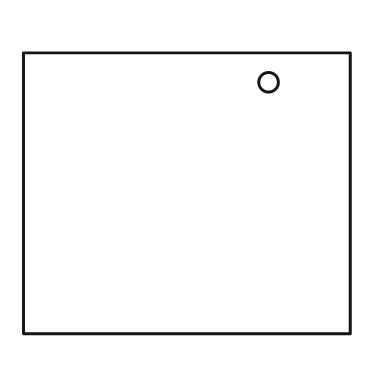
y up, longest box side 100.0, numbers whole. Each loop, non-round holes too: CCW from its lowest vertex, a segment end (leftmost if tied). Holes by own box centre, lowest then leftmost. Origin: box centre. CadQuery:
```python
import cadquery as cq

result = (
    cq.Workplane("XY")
    .moveTo(-50.0, -43.0)
    .lineTo(50.0, -43.0)
    .lineTo(50.0, 43.0)
    .lineTo(-50.0, 43.0)
    .close()
    .moveTo(25.0, 34.0)
    .circle(3.0)
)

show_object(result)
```